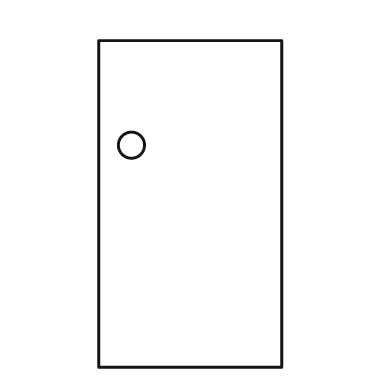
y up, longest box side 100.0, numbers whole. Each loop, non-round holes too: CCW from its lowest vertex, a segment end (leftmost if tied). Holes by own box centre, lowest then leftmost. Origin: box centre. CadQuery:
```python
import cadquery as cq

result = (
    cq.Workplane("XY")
    .moveTo(-28.0, -50.0)
    .lineTo(28.0, -50.0)
    .lineTo(28.0, 50.0)
    .lineTo(-28.0, 50.0)
    .close()
    .moveTo(-18.0, 18.0)
    .circle(4.0)
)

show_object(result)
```